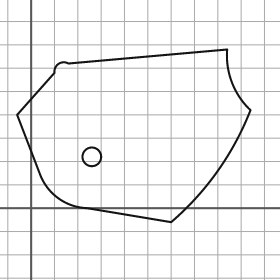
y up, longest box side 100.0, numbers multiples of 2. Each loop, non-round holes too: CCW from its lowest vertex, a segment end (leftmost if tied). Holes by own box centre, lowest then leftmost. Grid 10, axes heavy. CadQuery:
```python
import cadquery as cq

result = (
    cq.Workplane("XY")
    .moveTo(60.0, -6.0)
    .threePointArc((80.0, 16.0), (94.0, 42.0))
    .threePointArc((86.0, 54.0), (84.0, 68.0))
    .lineTo(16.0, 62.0)
    .threePointArc((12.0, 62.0), (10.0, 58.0))
    .lineTo(-6.0, 40.0)
    .lineTo(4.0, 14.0)
    .threePointArc((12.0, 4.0), (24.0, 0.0))
    .close()
    .moveTo(26.0, 22.0)
    .circle(4.0)
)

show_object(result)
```